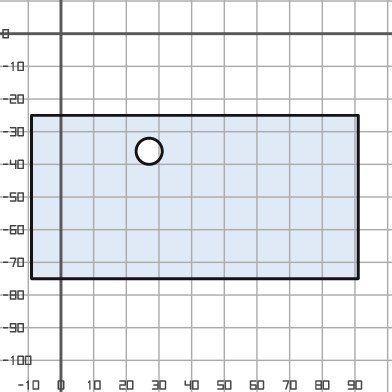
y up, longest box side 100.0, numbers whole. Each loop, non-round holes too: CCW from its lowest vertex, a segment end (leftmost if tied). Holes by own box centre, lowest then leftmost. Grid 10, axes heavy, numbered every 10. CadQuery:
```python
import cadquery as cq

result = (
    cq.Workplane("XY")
    .moveTo(-9.0, -75.0)
    .lineTo(91.0, -75.0)
    .lineTo(91.0, -25.0)
    .lineTo(-9.0, -25.0)
    .close()
    .moveTo(27.0, -36.0)
    .circle(4.0)
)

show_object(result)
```